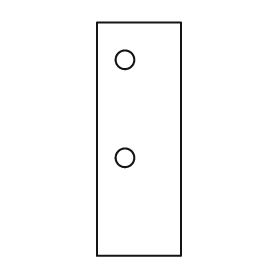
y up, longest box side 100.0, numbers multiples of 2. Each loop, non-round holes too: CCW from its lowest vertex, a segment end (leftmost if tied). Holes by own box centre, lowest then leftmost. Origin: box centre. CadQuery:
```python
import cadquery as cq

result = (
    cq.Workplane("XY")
    .moveTo(-18.0, -50.0)
    .lineTo(18.0, -50.0)
    .lineTo(18.0, 50.0)
    .lineTo(-18.0, 50.0)
    .close()
    .moveTo(-6.0, -8.0)
    .circle(4.0)
    .moveTo(-6.0, 34.0)
    .circle(4.0)
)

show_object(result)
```